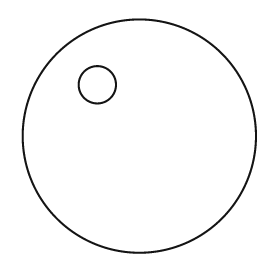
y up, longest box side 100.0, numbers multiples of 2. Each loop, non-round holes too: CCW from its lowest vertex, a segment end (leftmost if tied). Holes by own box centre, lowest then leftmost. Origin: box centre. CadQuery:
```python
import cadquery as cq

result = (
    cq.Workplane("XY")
    .moveTo(0.0, 0.0)
    .circle(50.0)
    .moveTo(-18.0, 22.0)
    .circle(8.0)
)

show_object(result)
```